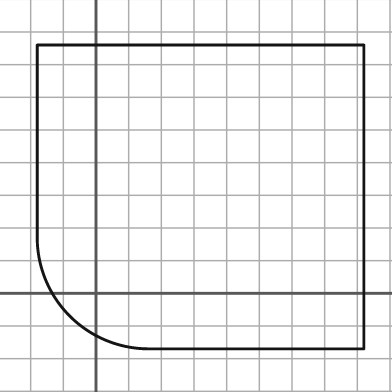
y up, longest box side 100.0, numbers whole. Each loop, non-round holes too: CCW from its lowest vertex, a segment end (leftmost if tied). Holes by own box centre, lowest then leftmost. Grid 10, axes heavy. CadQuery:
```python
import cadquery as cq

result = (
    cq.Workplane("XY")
    .moveTo(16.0, -17.0)
    .lineTo(82.0, -17.0)
    .lineTo(82.0, 76.0)
    .lineTo(-18.0, 76.0)
    .lineTo(-18.0, 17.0)
    .threePointArc((-8.0, -7.0), (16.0, -17.0))
    .close()
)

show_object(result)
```